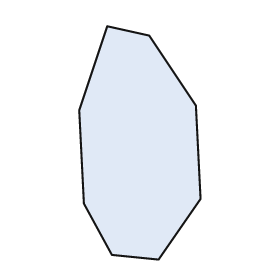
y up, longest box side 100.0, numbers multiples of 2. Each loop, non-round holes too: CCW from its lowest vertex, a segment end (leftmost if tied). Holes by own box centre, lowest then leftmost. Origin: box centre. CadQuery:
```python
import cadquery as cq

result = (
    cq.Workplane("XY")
    .moveTo(8.0, -50.0)
    .lineTo(26.0, -24.0)
    .lineTo(24.0, 16.0)
    .lineTo(4.0, 46.0)
    .lineTo(-14.0, 50.0)
    .lineTo(-26.0, 14.0)
    .lineTo(-24.0, -26.0)
    .lineTo(-12.0, -48.0)
    .close()
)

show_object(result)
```